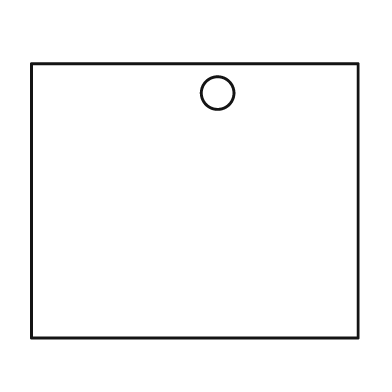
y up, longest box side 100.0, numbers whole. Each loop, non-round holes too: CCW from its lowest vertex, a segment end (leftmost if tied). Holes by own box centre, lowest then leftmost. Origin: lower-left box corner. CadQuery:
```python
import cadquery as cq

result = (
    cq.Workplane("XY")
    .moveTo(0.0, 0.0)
    .lineTo(100.0, 0.0)
    .lineTo(100.0, 84.0)
    .lineTo(0.0, 84.0)
    .close()
    .moveTo(57.0, 75.0)
    .circle(5.0)
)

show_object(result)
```